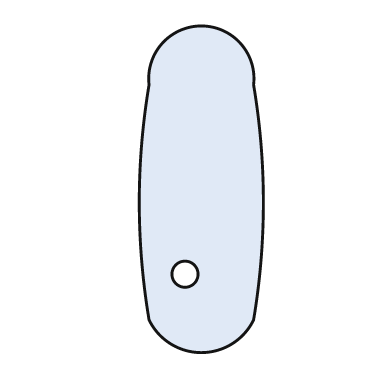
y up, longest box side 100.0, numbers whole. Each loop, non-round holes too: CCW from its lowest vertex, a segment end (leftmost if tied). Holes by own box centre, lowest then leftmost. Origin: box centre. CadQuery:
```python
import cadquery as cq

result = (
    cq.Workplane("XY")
    .moveTo(-16.0, -40.0)
    .threePointArc((0.0, -50.0), (16.0, -40.0))
    .threePointArc((19.0, -4.0), (16.0, 32.0))
    .threePointArc((0.0, 50.0), (-16.0, 32.0))
    .threePointArc((-19.0, -4.0), (-16.0, -40.0))
    .close()
    .moveTo(-5.0, -26.0)
    .circle(4.0)
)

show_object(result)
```